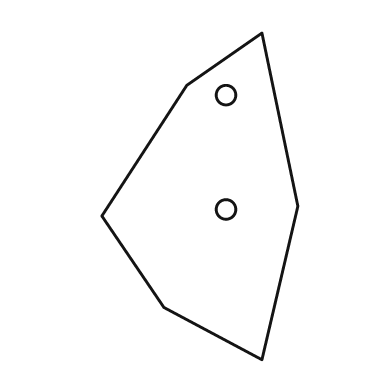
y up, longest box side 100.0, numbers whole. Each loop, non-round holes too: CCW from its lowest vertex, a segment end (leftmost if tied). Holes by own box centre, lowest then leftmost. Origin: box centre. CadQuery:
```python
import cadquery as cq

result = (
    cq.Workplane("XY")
    .moveTo(19.0, -50.0)
    .lineTo(30.0, -3.0)
    .lineTo(19.0, 50.0)
    .lineTo(-4.0, 34.0)
    .lineTo(-30.0, -6.0)
    .lineTo(-11.0, -34.0)
    .close()
    .moveTo(8.0, -4.0)
    .circle(3.0)
    .moveTo(8.0, 31.0)
    .circle(3.0)
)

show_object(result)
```